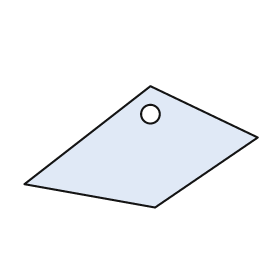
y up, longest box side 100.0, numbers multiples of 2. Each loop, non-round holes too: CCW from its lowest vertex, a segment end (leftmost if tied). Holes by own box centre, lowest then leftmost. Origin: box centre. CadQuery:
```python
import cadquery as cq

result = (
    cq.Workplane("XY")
    .moveTo(6.0, -26.0)
    .lineTo(50.0, 4.0)
    .lineTo(4.0, 26.0)
    .lineTo(-50.0, -16.0)
    .close()
    .moveTo(4.0, 14.0)
    .circle(4.0)
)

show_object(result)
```